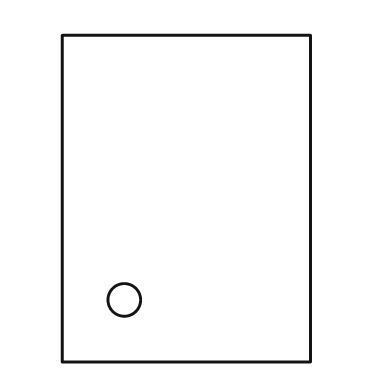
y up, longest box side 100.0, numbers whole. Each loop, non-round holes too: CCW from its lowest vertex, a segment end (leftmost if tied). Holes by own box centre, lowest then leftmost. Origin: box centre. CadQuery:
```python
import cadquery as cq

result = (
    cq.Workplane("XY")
    .moveTo(-38.0, -50.0)
    .lineTo(38.0, -50.0)
    .lineTo(38.0, 50.0)
    .lineTo(-38.0, 50.0)
    .close()
    .moveTo(-19.0, -31.0)
    .circle(5.0)
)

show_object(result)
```